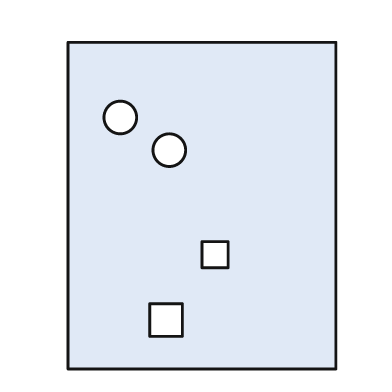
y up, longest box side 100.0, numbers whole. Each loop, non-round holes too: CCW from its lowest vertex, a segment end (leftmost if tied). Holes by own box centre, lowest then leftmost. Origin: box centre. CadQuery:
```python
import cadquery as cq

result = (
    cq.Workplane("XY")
    .moveTo(-41.0, -50.0)
    .lineTo(41.0, -50.0)
    .lineTo(41.0, 50.0)
    .lineTo(-41.0, 50.0)
    .close()
    .moveTo(-16.0, -40.0)
    .lineTo(-6.0, -40.0)
    .lineTo(-6.0, -30.0)
    .lineTo(-16.0, -30.0)
    .close()
    .moveTo(0.0, -19.0)
    .lineTo(8.0, -19.0)
    .lineTo(8.0, -11.0)
    .lineTo(0.0, -11.0)
    .close()
    .moveTo(-10.0, 17.0)
    .circle(5.0)
    .moveTo(-25.0, 27.0)
    .circle(5.0)
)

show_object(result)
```